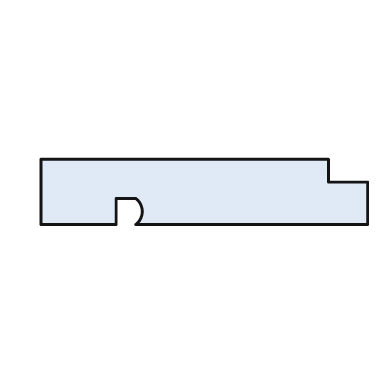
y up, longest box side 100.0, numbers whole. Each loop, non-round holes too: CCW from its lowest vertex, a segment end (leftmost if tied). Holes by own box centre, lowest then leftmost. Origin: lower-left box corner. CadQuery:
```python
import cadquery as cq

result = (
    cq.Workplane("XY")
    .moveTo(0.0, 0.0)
    .lineTo(23.0, 0.0)
    .lineTo(23.0, 8.0)
    .lineTo(29.0, 8.0)
    .threePointArc((31.0, 4.0), (29.0, 0.0))
    .lineTo(100.0, 0.0)
    .lineTo(100.0, 13.0)
    .lineTo(88.0, 13.0)
    .lineTo(88.0, 20.0)
    .lineTo(0.0, 20.0)
    .close()
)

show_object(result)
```